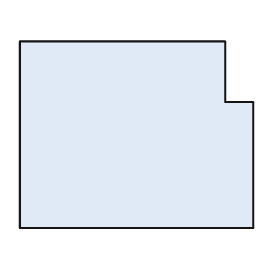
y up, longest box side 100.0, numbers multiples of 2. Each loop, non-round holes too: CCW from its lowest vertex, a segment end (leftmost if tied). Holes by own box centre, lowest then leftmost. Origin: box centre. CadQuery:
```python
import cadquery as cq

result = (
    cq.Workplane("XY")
    .moveTo(-50.0, -40.0)
    .lineTo(50.0, -40.0)
    .lineTo(50.0, 14.0)
    .lineTo(38.0, 14.0)
    .lineTo(38.0, 40.0)
    .lineTo(-50.0, 40.0)
    .close()
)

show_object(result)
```